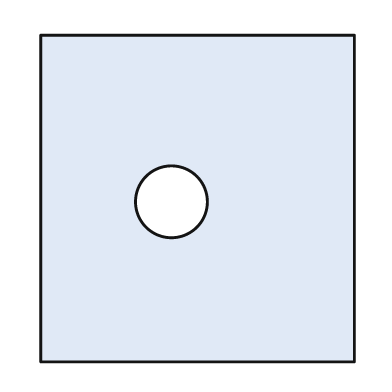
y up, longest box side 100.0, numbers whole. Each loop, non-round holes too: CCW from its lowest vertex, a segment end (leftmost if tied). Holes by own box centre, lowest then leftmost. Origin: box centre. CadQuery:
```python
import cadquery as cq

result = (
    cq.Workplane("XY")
    .moveTo(-48.0, -50.0)
    .lineTo(48.0, -50.0)
    .lineTo(48.0, 50.0)
    .lineTo(-48.0, 50.0)
    .close()
    .moveTo(-8.0, -1.0)
    .circle(11.0)
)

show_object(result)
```